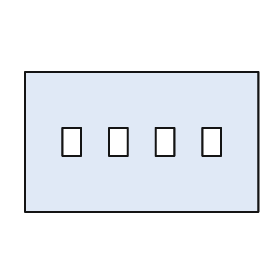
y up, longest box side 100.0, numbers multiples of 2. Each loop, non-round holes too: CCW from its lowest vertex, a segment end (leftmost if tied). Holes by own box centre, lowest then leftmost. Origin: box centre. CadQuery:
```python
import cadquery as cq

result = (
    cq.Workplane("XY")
    .moveTo(-50.0, -30.0)
    .lineTo(50.0, -30.0)
    .lineTo(50.0, 30.0)
    .lineTo(-50.0, 30.0)
    .close()
    .moveTo(-34.0, -6.0)
    .lineTo(-26.0, -6.0)
    .lineTo(-26.0, 6.0)
    .lineTo(-34.0, 6.0)
    .close()
    .moveTo(-14.0, -6.0)
    .lineTo(-6.0, -6.0)
    .lineTo(-6.0, 6.0)
    .lineTo(-14.0, 6.0)
    .close()
    .moveTo(6.0, -6.0)
    .lineTo(14.0, -6.0)
    .lineTo(14.0, 6.0)
    .lineTo(6.0, 6.0)
    .close()
    .moveTo(26.0, -6.0)
    .lineTo(34.0, -6.0)
    .lineTo(34.0, 6.0)
    .lineTo(26.0, 6.0)
    .close()
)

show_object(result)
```